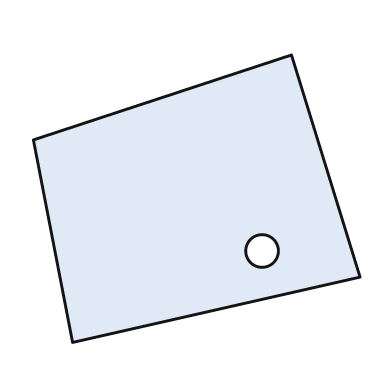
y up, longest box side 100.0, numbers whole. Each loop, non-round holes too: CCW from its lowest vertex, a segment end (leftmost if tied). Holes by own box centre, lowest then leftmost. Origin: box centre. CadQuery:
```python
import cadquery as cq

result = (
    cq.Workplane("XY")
    .moveTo(-38.0, -44.0)
    .lineTo(50.0, -24.0)
    .lineTo(29.0, 44.0)
    .lineTo(-50.0, 18.0)
    .close()
    .moveTo(20.0, -16.0)
    .circle(5.0)
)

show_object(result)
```